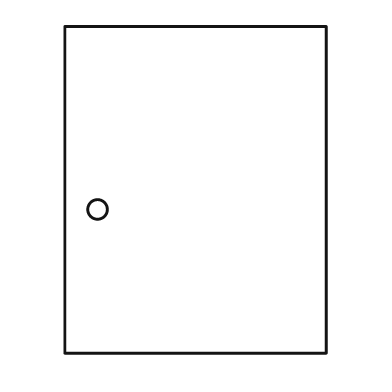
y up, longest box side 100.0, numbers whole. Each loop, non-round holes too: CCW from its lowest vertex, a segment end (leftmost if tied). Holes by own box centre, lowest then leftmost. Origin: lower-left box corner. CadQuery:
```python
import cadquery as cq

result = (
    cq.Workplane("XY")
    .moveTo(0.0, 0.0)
    .lineTo(80.0, 0.0)
    .lineTo(80.0, 100.0)
    .lineTo(0.0, 100.0)
    .close()
    .moveTo(10.0, 44.0)
    .circle(3.0)
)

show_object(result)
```